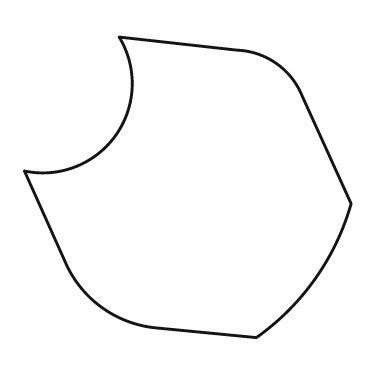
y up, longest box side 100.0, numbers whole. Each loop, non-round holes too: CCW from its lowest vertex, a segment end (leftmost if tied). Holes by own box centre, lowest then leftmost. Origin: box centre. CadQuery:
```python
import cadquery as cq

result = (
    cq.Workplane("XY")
    .moveTo(21.0, -46.0)
    .threePointArc((39.0, -28.0), (50.0, -5.0))
    .lineTo(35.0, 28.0)
    .threePointArc((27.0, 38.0), (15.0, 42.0))
    .lineTo(-21.0, 46.0)
    .threePointArc((-22.0, 16.0), (-50.0, 5.0))
    .lineTo(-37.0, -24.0)
    .threePointArc((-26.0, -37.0), (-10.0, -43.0))
    .close()
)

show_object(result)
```